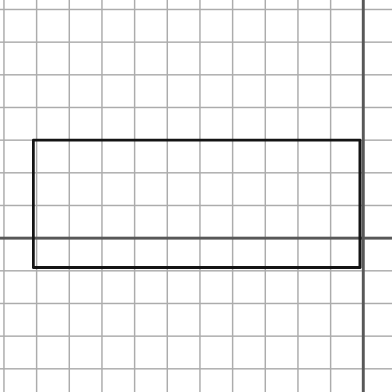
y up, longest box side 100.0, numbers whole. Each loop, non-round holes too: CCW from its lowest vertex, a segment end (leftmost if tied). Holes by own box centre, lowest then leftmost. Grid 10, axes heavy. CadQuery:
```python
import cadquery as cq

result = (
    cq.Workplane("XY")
    .moveTo(-101.0, -9.0)
    .lineTo(-1.0, -9.0)
    .lineTo(-1.0, 30.0)
    .lineTo(-101.0, 30.0)
    .close()
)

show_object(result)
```